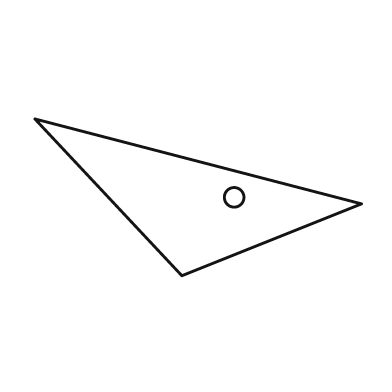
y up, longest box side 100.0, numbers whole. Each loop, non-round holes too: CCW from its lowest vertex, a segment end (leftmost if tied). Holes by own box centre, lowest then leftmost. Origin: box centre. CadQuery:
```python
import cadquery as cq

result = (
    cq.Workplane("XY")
    .moveTo(-5.0, -24.0)
    .lineTo(50.0, -2.0)
    .lineTo(-50.0, 24.0)
    .close()
    .moveTo(11.0, 0.0)
    .circle(3.0)
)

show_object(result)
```